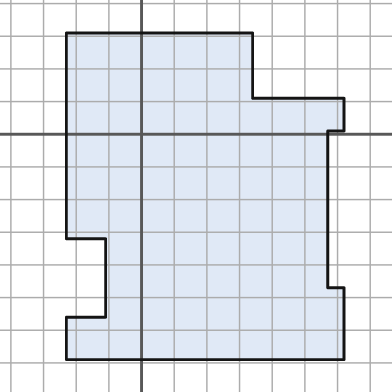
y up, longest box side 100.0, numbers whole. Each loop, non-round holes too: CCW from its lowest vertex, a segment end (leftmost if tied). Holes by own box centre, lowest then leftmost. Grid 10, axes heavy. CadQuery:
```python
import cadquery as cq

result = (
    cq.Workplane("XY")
    .moveTo(-23.0, -69.0)
    .lineTo(62.0, -69.0)
    .lineTo(62.0, -47.0)
    .lineTo(57.0, -47.0)
    .lineTo(57.0, 1.0)
    .lineTo(62.0, 1.0)
    .lineTo(62.0, 11.0)
    .lineTo(34.0, 11.0)
    .lineTo(34.0, 31.0)
    .lineTo(-23.0, 31.0)
    .lineTo(-23.0, -32.0)
    .lineTo(-11.0, -32.0)
    .lineTo(-11.0, -56.0)
    .lineTo(-23.0, -56.0)
    .close()
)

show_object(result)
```